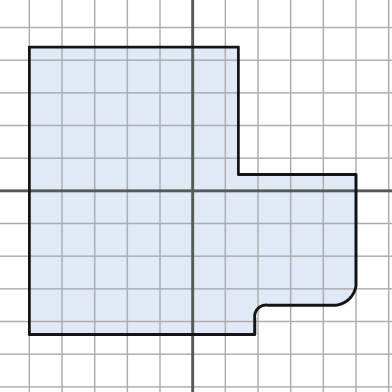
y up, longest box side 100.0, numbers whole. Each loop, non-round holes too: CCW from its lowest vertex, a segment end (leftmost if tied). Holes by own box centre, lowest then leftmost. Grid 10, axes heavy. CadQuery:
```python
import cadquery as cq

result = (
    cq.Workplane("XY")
    .moveTo(-50.0, -44.0)
    .lineTo(19.0, -44.0)
    .lineTo(19.0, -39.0)
    .threePointArc((20.0, -36.0), (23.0, -35.0))
    .lineTo(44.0, -35.0)
    .threePointArc((48.0, -33.0), (50.0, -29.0))
    .lineTo(50.0, 5.0)
    .lineTo(14.0, 5.0)
    .lineTo(14.0, 44.0)
    .lineTo(-50.0, 44.0)
    .close()
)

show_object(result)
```